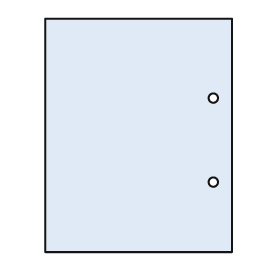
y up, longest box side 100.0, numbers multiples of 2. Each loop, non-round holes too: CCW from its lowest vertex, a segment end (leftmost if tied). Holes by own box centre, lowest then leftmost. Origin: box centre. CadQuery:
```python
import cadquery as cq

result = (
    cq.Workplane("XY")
    .moveTo(-40.0, -50.0)
    .lineTo(40.0, -50.0)
    .lineTo(40.0, 50.0)
    .lineTo(-40.0, 50.0)
    .close()
    .moveTo(32.0, -20.0)
    .circle(2.0)
    .moveTo(32.0, 16.0)
    .circle(2.0)
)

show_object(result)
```